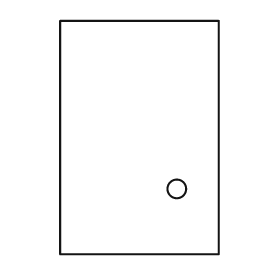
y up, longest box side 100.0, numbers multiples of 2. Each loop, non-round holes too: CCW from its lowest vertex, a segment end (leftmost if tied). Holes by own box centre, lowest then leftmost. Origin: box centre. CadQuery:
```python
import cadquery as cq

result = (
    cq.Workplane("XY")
    .moveTo(-34.0, -50.0)
    .lineTo(34.0, -50.0)
    .lineTo(34.0, 50.0)
    .lineTo(-34.0, 50.0)
    .close()
    .moveTo(16.0, -22.0)
    .circle(4.0)
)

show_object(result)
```